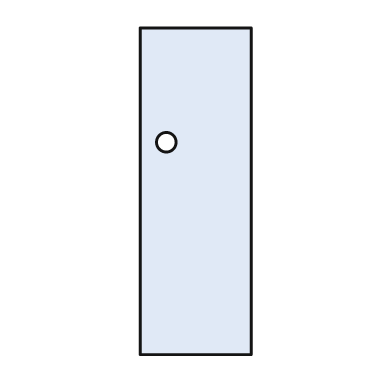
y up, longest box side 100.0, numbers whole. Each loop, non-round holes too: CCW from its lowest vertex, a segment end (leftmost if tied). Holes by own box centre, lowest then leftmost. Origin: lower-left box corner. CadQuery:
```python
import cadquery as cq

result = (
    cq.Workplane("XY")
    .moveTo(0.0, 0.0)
    .lineTo(34.0, 0.0)
    .lineTo(34.0, 100.0)
    .lineTo(0.0, 100.0)
    .close()
    .moveTo(8.0, 65.0)
    .circle(3.0)
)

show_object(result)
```